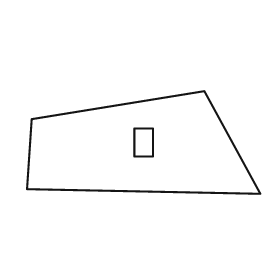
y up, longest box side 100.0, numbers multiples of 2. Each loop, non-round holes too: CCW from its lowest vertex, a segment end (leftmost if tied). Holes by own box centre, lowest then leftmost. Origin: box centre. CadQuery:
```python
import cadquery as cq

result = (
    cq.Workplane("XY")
    .moveTo(50.0, -22.0)
    .lineTo(26.0, 22.0)
    .lineTo(-48.0, 10.0)
    .lineTo(-50.0, -20.0)
    .close()
    .moveTo(-4.0, -6.0)
    .lineTo(4.0, -6.0)
    .lineTo(4.0, 6.0)
    .lineTo(-4.0, 6.0)
    .close()
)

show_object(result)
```